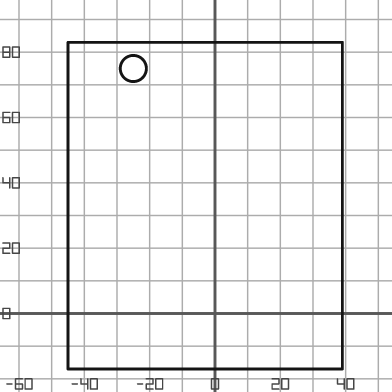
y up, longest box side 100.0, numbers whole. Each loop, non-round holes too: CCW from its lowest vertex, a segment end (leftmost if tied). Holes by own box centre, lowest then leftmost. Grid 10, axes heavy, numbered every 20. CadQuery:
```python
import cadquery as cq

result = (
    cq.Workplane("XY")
    .moveTo(-45.0, -17.0)
    .lineTo(39.0, -17.0)
    .lineTo(39.0, 83.0)
    .lineTo(-45.0, 83.0)
    .close()
    .moveTo(-25.0, 75.0)
    .circle(4.0)
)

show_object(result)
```